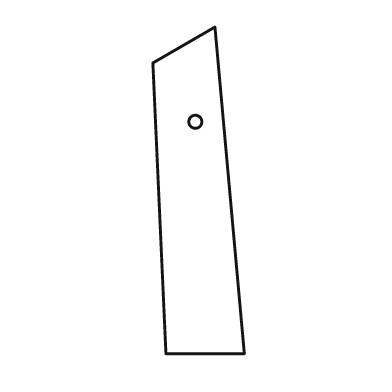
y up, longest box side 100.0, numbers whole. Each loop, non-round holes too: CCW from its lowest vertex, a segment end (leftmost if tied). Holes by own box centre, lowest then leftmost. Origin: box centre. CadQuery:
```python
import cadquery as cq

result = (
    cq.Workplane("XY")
    .moveTo(-10.0, -50.0)
    .lineTo(14.0, -50.0)
    .lineTo(5.0, 50.0)
    .lineTo(-14.0, 39.0)
    .close()
    .moveTo(-1.0, 21.0)
    .circle(2.0)
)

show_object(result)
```